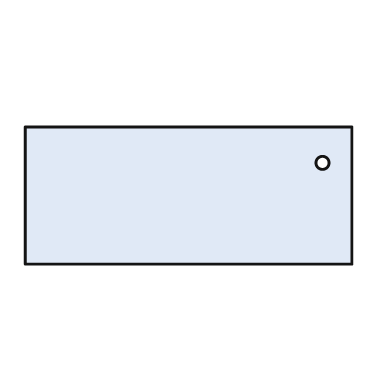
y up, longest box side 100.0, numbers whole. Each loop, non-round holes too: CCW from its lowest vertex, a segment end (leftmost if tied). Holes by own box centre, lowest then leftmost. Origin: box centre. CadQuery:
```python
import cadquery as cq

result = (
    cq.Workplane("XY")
    .moveTo(-50.0, -21.0)
    .lineTo(50.0, -21.0)
    .lineTo(50.0, 21.0)
    .lineTo(-50.0, 21.0)
    .close()
    .moveTo(41.0, 10.0)
    .circle(2.0)
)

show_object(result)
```